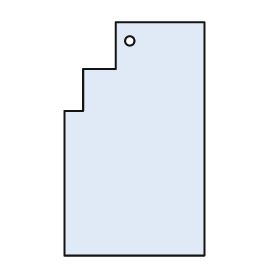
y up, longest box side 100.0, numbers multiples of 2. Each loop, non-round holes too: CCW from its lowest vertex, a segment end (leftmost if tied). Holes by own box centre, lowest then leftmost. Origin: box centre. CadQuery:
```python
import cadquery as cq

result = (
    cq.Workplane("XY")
    .moveTo(-30.0, -50.0)
    .lineTo(30.0, -50.0)
    .lineTo(30.0, 50.0)
    .lineTo(-8.0, 50.0)
    .lineTo(-8.0, 30.0)
    .lineTo(-22.0, 30.0)
    .lineTo(-22.0, 12.0)
    .lineTo(-30.0, 12.0)
    .close()
    .moveTo(-2.0, 42.0)
    .circle(2.0)
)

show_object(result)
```